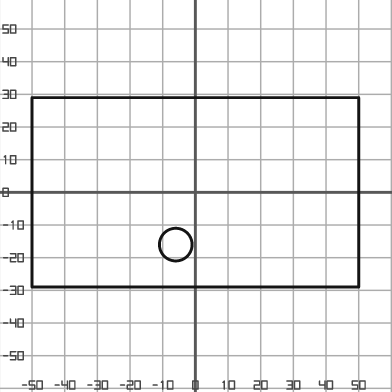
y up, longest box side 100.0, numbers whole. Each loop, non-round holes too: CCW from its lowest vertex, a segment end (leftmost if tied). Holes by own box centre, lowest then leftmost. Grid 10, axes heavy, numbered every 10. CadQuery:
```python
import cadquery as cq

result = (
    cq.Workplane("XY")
    .moveTo(-50.0, -29.0)
    .lineTo(50.0, -29.0)
    .lineTo(50.0, 29.0)
    .lineTo(-50.0, 29.0)
    .close()
    .moveTo(-6.0, -16.0)
    .circle(5.0)
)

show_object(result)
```